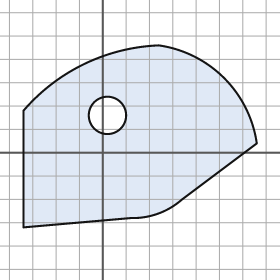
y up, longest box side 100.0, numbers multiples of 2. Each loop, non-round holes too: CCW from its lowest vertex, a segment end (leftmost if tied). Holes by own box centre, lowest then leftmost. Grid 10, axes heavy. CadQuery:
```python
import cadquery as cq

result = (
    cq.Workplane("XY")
    .moveTo(-34.0, -32.0)
    .lineTo(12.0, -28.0)
    .threePointArc((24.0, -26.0), (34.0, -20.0))
    .lineTo(66.0, 4.0)
    .threePointArc((52.0, 32.0), (24.0, 46.0))
    .threePointArc((-8.0, 38.0), (-34.0, 18.0))
    .close()
    .moveTo(2.0, 16.0)
    .circle(8.0)
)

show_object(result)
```